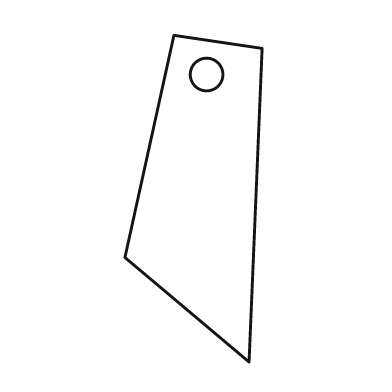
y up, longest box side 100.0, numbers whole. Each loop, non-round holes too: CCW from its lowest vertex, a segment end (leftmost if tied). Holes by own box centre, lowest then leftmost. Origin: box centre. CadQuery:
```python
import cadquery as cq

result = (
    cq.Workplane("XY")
    .moveTo(17.0, -50.0)
    .lineTo(21.0, 46.0)
    .lineTo(-6.0, 50.0)
    .lineTo(-21.0, -18.0)
    .close()
    .moveTo(4.0, 38.0)
    .circle(5.0)
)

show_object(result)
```